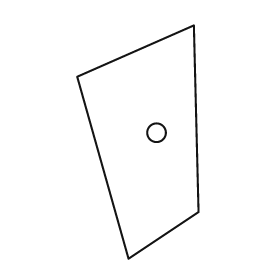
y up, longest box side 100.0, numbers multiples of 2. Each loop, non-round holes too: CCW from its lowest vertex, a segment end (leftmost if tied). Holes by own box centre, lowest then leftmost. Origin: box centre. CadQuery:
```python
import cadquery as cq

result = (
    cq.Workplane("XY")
    .moveTo(-4.0, -50.0)
    .lineTo(26.0, -30.0)
    .lineTo(24.0, 50.0)
    .lineTo(-26.0, 28.0)
    .close()
    .moveTo(8.0, 4.0)
    .circle(4.0)
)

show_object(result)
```